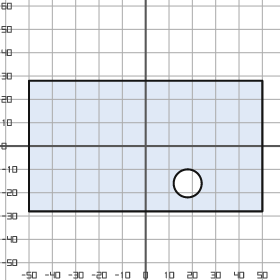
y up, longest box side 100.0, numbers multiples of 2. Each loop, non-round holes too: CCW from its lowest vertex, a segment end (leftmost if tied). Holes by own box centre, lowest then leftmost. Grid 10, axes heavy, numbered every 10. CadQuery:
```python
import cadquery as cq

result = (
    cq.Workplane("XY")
    .moveTo(-50.0, -28.0)
    .lineTo(50.0, -28.0)
    .lineTo(50.0, 28.0)
    .lineTo(-50.0, 28.0)
    .close()
    .moveTo(18.0, -16.0)
    .circle(6.0)
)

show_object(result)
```